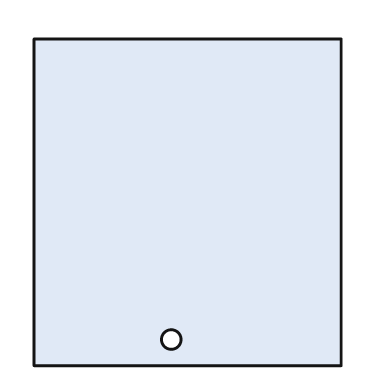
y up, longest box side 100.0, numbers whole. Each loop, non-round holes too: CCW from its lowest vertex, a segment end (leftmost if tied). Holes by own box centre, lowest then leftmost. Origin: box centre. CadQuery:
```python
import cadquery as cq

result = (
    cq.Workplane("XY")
    .moveTo(-47.0, -50.0)
    .lineTo(47.0, -50.0)
    .lineTo(47.0, 50.0)
    .lineTo(-47.0, 50.0)
    .close()
    .moveTo(-5.0, -42.0)
    .circle(3.0)
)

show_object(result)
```